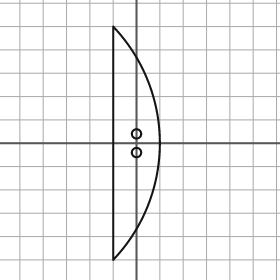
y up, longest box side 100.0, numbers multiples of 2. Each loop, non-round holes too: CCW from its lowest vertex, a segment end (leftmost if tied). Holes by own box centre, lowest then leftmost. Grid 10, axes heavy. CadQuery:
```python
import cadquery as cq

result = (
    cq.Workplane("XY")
    .moveTo(-10.0, -50.0)
    .threePointArc((10.0, 0.0), (-10.0, 50.0))
    .close()
    .moveTo(0.0, -4.0)
    .circle(2.0)
    .moveTo(0.0, 4.0)
    .circle(2.0)
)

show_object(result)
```